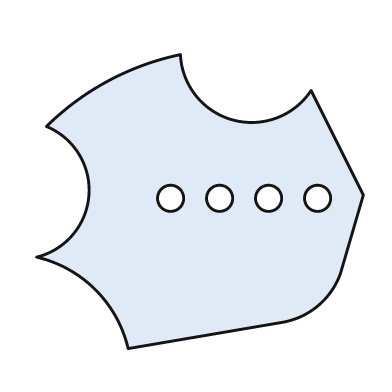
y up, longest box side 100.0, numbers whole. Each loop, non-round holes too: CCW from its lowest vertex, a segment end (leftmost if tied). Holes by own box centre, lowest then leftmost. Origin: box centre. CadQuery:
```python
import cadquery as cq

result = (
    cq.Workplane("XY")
    .moveTo(-22.0, -45.0)
    .lineTo(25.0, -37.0)
    .threePointArc((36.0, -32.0), (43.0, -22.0))
    .lineTo(50.0, 2.0)
    .lineTo(34.0, 34.0)
    .threePointArc((10.0, 25.0), (-6.0, 45.0))
    .threePointArc((-28.0, 37.0), (-47.0, 23.0))
    .threePointArc((-34.0, 2.0), (-50.0, -17.0))
    .threePointArc((-32.0, -27.0), (-22.0, -45.0))
    .close()
    .moveTo(-9.0, 1.0)
    .circle(4.0)
    .moveTo(6.0, 1.0)
    .circle(4.0)
    .moveTo(21.0, 1.0)
    .circle(4.0)
    .moveTo(36.0, 1.0)
    .circle(4.0)
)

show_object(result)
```